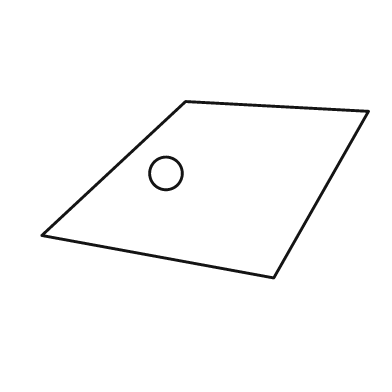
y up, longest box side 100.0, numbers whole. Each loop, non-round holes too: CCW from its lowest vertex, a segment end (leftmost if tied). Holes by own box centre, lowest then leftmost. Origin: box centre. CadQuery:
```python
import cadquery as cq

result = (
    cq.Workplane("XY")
    .moveTo(21.0, -27.0)
    .lineTo(50.0, 24.0)
    .lineTo(-6.0, 27.0)
    .lineTo(-50.0, -14.0)
    .close()
    .moveTo(-12.0, 5.0)
    .circle(5.0)
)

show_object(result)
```